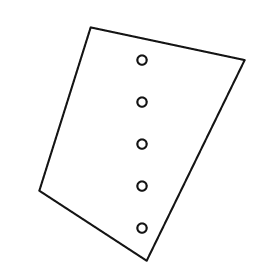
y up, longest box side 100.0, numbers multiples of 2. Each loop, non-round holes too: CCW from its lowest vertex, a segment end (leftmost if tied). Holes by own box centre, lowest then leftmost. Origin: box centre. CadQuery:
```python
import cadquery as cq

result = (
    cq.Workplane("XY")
    .moveTo(2.0, -50.0)
    .lineTo(44.0, 36.0)
    .lineTo(-22.0, 50.0)
    .lineTo(-44.0, -20.0)
    .close()
    .moveTo(0.0, -36.0)
    .circle(2.0)
    .moveTo(0.0, -18.0)
    .circle(2.0)
    .moveTo(0.0, 0.0)
    .circle(2.0)
    .moveTo(0.0, 18.0)
    .circle(2.0)
    .moveTo(0.0, 36.0)
    .circle(2.0)
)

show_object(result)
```